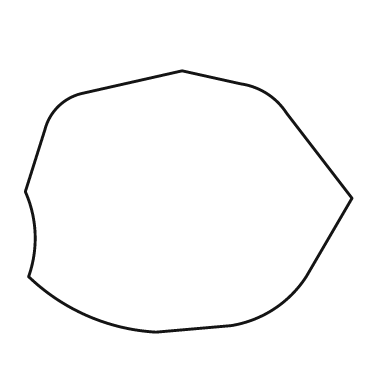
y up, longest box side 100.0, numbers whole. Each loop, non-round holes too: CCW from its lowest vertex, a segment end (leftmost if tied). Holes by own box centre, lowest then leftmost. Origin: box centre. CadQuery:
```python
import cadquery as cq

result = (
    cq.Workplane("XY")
    .moveTo(-10.0, -40.0)
    .lineTo(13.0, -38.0)
    .threePointArc((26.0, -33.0), (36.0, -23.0))
    .lineTo(50.0, 1.0)
    .lineTo(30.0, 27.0)
    .threePointArc((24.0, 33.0), (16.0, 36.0))
    .lineTo(-2.0, 40.0)
    .lineTo(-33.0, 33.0)
    .threePointArc((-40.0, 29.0), (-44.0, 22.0))
    .lineTo(-50.0, 3.0)
    .threePointArc((-47.0, -10.0), (-49.0, -23.0))
    .threePointArc((-31.0, -35.0), (-10.0, -40.0))
    .close()
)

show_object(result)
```